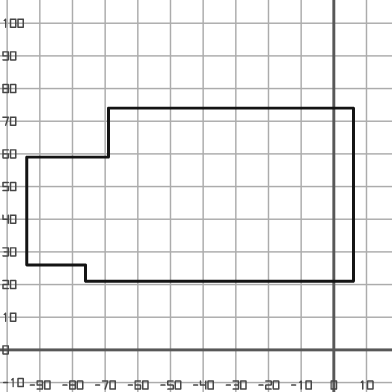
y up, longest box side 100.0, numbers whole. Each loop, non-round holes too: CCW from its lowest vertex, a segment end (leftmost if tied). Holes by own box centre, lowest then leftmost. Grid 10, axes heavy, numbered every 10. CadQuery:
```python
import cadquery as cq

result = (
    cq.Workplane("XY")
    .moveTo(-76.0, 21.0)
    .lineTo(6.0, 21.0)
    .lineTo(6.0, 74.0)
    .lineTo(-69.0, 74.0)
    .lineTo(-69.0, 59.0)
    .lineTo(-94.0, 59.0)
    .lineTo(-94.0, 26.0)
    .lineTo(-76.0, 26.0)
    .close()
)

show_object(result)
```